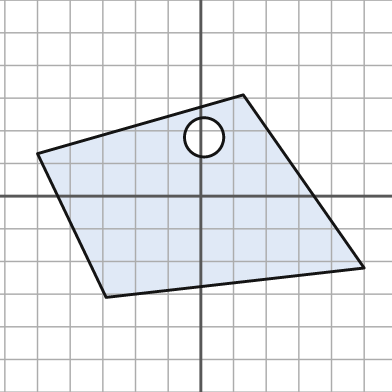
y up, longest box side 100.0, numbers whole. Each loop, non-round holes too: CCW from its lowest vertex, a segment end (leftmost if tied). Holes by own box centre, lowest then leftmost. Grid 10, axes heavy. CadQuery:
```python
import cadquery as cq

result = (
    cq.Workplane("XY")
    .moveTo(-29.0, -31.0)
    .lineTo(50.0, -22.0)
    .lineTo(13.0, 31.0)
    .lineTo(-50.0, 13.0)
    .close()
    .moveTo(1.0, 18.0)
    .circle(6.0)
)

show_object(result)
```